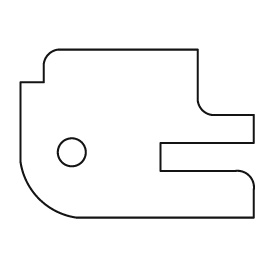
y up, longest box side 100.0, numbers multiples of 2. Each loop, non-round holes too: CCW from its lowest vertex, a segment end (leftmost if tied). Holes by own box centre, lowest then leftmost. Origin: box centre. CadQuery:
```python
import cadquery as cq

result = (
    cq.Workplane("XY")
    .moveTo(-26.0, -36.0)
    .lineTo(50.0, -36.0)
    .lineTo(50.0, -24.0)
    .threePointArc((48.0, -18.0), (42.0, -16.0))
    .lineTo(10.0, -16.0)
    .lineTo(10.0, -4.0)
    .lineTo(50.0, -4.0)
    .lineTo(50.0, 8.0)
    .lineTo(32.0, 8.0)
    .threePointArc((28.0, 10.0), (26.0, 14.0))
    .lineTo(26.0, 36.0)
    .lineTo(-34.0, 36.0)
    .threePointArc((-38.0, 34.0), (-40.0, 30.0))
    .lineTo(-40.0, 22.0)
    .lineTo(-50.0, 22.0)
    .lineTo(-50.0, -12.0)
    .threePointArc((-42.0, -28.0), (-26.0, -36.0))
    .close()
    .moveTo(-28.0, -8.0)
    .circle(6.0)
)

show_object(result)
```